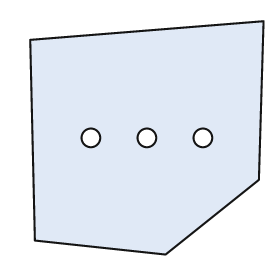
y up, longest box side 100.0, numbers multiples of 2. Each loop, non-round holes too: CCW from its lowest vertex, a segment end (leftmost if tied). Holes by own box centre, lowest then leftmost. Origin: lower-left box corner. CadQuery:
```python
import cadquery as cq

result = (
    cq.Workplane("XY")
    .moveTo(58.0, 0.0)
    .lineTo(98.0, 32.0)
    .lineTo(100.0, 100.0)
    .lineTo(0.0, 92.0)
    .lineTo(2.0, 6.0)
    .close()
    .moveTo(26.0, 50.0)
    .circle(4.0)
    .moveTo(50.0, 50.0)
    .circle(4.0)
    .moveTo(74.0, 50.0)
    .circle(4.0)
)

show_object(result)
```